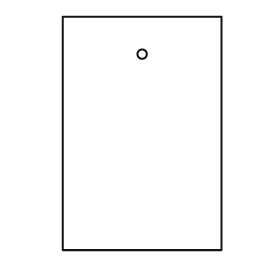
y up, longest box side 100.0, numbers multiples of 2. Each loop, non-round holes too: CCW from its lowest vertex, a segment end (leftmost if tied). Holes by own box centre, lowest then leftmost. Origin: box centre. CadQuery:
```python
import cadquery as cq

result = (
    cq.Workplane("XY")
    .moveTo(-34.0, -50.0)
    .lineTo(34.0, -50.0)
    .lineTo(34.0, 50.0)
    .lineTo(-34.0, 50.0)
    .close()
    .moveTo(0.0, 34.0)
    .circle(2.0)
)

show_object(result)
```